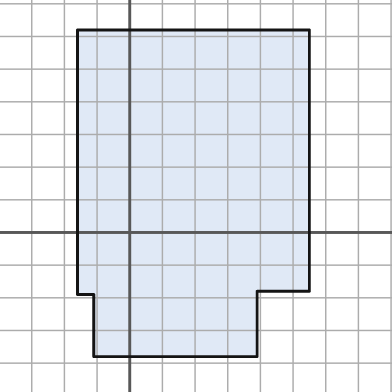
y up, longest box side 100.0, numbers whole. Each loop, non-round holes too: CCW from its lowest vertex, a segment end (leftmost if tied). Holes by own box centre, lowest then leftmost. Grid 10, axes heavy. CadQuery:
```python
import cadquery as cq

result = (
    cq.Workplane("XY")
    .moveTo(-11.0, -38.0)
    .lineTo(39.0, -38.0)
    .lineTo(39.0, -18.0)
    .lineTo(55.0, -18.0)
    .lineTo(55.0, 62.0)
    .lineTo(-16.0, 62.0)
    .lineTo(-16.0, -19.0)
    .lineTo(-11.0, -19.0)
    .close()
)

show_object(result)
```